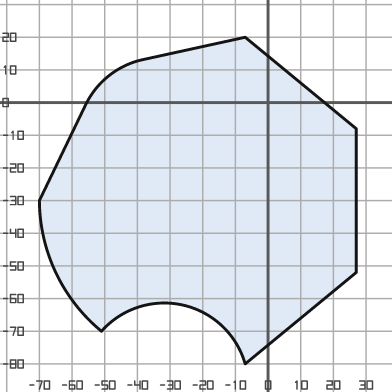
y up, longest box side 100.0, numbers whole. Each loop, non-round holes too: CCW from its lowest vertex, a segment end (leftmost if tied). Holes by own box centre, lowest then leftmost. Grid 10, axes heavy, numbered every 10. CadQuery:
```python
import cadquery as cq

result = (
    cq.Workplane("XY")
    .moveTo(-7.0, -80.0)
    .lineTo(27.0, -52.0)
    .lineTo(27.0, -8.0)
    .lineTo(-7.0, 20.0)
    .lineTo(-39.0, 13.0)
    .threePointArc((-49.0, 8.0), (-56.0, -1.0))
    .lineTo(-70.0, -30.0)
    .threePointArc((-65.0, -52.0), (-51.0, -70.0))
    .threePointArc((-26.0, -62.0), (-7.0, -80.0))
    .close()
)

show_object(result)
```